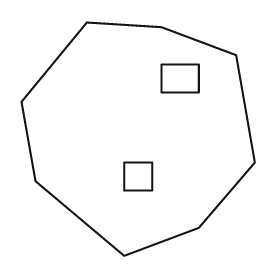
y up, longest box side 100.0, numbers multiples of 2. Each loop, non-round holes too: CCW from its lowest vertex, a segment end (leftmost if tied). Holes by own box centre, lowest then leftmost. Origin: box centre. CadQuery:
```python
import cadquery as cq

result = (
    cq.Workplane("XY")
    .moveTo(-6.0, -50.0)
    .lineTo(26.0, -38.0)
    .lineTo(50.0, -10.0)
    .lineTo(42.0, 36.0)
    .lineTo(10.0, 48.0)
    .lineTo(-22.0, 50.0)
    .lineTo(-50.0, 16.0)
    .lineTo(-44.0, -18.0)
    .close()
    .moveTo(-6.0, -22.0)
    .lineTo(6.0, -22.0)
    .lineTo(6.0, -10.0)
    .lineTo(-6.0, -10.0)
    .close()
    .moveTo(10.0, 20.0)
    .lineTo(26.0, 20.0)
    .lineTo(26.0, 32.0)
    .lineTo(10.0, 32.0)
    .close()
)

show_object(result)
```